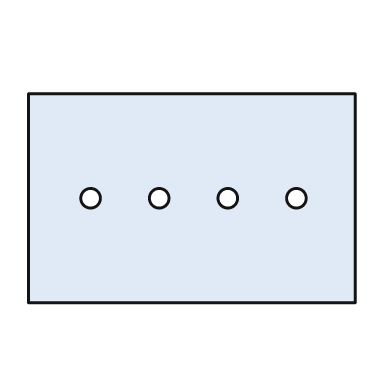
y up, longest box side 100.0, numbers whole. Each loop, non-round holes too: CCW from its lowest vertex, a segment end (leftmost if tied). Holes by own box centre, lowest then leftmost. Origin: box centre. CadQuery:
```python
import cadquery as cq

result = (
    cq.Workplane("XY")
    .moveTo(-50.0, -32.0)
    .lineTo(50.0, -32.0)
    .lineTo(50.0, 32.0)
    .lineTo(-50.0, 32.0)
    .close()
    .moveTo(-31.0, 0.0)
    .circle(3.0)
    .moveTo(-10.0, 0.0)
    .circle(3.0)
    .moveTo(11.0, 0.0)
    .circle(3.0)
    .moveTo(32.0, 0.0)
    .circle(3.0)
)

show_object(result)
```